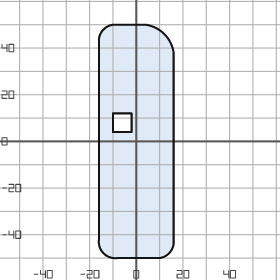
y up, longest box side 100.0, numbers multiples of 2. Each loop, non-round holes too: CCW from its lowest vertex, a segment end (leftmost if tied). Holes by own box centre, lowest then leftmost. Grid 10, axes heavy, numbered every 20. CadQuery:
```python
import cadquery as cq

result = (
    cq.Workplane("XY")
    .moveTo(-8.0, -50.0)
    .lineTo(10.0, -50.0)
    .threePointArc((14.0, -48.0), (16.0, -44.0))
    .lineTo(16.0, 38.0)
    .threePointArc((12.0, 46.0), (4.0, 50.0))
    .lineTo(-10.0, 50.0)
    .threePointArc((-14.0, 48.0), (-16.0, 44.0))
    .lineTo(-16.0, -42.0)
    .threePointArc((-14.0, -48.0), (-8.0, -50.0))
    .close()
    .moveTo(-10.0, 4.0)
    .lineTo(-2.0, 4.0)
    .lineTo(-2.0, 12.0)
    .lineTo(-10.0, 12.0)
    .close()
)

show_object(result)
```